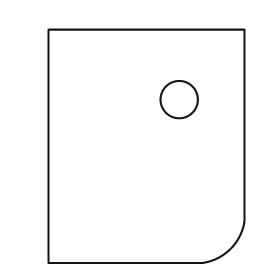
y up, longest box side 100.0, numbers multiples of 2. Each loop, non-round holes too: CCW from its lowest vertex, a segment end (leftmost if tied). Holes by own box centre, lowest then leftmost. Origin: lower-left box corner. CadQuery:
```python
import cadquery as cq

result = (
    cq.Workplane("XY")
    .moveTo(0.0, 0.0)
    .lineTo(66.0, 0.0)
    .threePointArc((78.0, 6.0), (84.0, 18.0))
    .lineTo(84.0, 100.0)
    .lineTo(0.0, 100.0)
    .close()
    .moveTo(56.0, 70.0)
    .circle(8.0)
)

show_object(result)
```